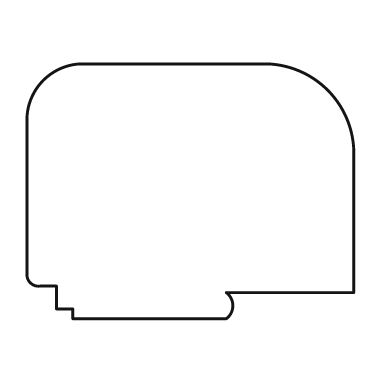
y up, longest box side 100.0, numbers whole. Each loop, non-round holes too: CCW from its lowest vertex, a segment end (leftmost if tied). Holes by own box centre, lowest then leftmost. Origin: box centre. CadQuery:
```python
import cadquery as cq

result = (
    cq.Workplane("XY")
    .moveTo(-36.0, -39.0)
    .lineTo(11.0, -39.0)
    .threePointArc((13.0, -35.0), (11.0, -31.0))
    .lineTo(50.0, -31.0)
    .lineTo(50.0, 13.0)
    .threePointArc((42.0, 31.0), (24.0, 39.0))
    .lineTo(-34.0, 39.0)
    .threePointArc((-45.0, 34.0), (-50.0, 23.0))
    .lineTo(-50.0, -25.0)
    .threePointArc((-49.0, -28.0), (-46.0, -29.0))
    .lineTo(-41.0, -29.0)
    .lineTo(-41.0, -36.0)
    .lineTo(-36.0, -36.0)
    .close()
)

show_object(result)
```